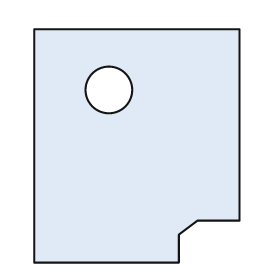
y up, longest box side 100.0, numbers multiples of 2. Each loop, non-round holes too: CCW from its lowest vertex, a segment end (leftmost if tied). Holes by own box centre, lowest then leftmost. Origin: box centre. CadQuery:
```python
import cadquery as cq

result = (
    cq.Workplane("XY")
    .moveTo(-44.0, -50.0)
    .lineTo(18.0, -50.0)
    .lineTo(18.0, -38.0)
    .lineTo(26.0, -32.0)
    .lineTo(44.0, -32.0)
    .lineTo(44.0, 50.0)
    .lineTo(-44.0, 50.0)
    .close()
    .moveTo(-12.0, 24.0)
    .circle(10.0)
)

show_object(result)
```